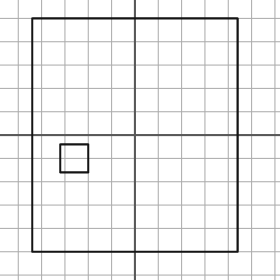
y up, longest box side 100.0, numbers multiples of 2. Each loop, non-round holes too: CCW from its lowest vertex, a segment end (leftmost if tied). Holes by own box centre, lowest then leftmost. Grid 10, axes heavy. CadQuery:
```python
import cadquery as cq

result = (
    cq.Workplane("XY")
    .moveTo(-44.0, -50.0)
    .lineTo(44.0, -50.0)
    .lineTo(44.0, 50.0)
    .lineTo(-44.0, 50.0)
    .close()
    .moveTo(-32.0, -16.0)
    .lineTo(-20.0, -16.0)
    .lineTo(-20.0, -4.0)
    .lineTo(-32.0, -4.0)
    .close()
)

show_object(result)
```